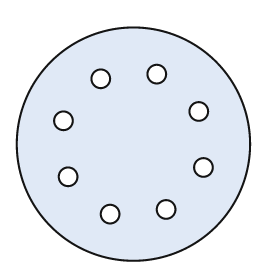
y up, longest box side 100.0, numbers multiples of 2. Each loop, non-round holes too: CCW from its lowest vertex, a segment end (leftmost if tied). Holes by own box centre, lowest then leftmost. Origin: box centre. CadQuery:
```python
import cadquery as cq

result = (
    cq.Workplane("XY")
    .moveTo(0.0, 0.0)
    .circle(50.0)
    .moveTo(-10.0, -30.0)
    .circle(4.0)
    .moveTo(14.0, -28.0)
    .circle(4.0)
    .moveTo(-28.0, -14.0)
    .circle(4.0)
    .moveTo(30.0, -10.0)
    .circle(4.0)
    .moveTo(-30.0, 10.0)
    .circle(4.0)
    .moveTo(28.0, 14.0)
    .circle(4.0)
    .moveTo(-14.0, 28.0)
    .circle(4.0)
    .moveTo(10.0, 30.0)
    .circle(4.0)
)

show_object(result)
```